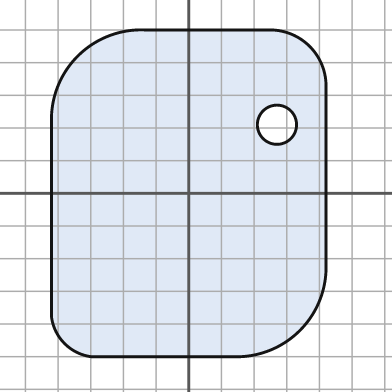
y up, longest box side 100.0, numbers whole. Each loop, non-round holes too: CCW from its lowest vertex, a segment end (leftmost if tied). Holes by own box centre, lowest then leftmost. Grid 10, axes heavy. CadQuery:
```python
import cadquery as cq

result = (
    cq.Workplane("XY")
    .moveTo(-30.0, -50.0)
    .lineTo(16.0, -50.0)
    .threePointArc((34.0, -42.0), (42.0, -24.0))
    .lineTo(42.0, 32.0)
    .threePointArc((37.0, 45.0), (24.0, 50.0))
    .lineTo(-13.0, 50.0)
    .threePointArc((-34.0, 42.0), (-42.0, 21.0))
    .lineTo(-42.0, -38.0)
    .threePointArc((-38.0, -46.0), (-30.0, -50.0))
    .close()
    .moveTo(27.0, 21.0)
    .circle(6.0)
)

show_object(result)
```